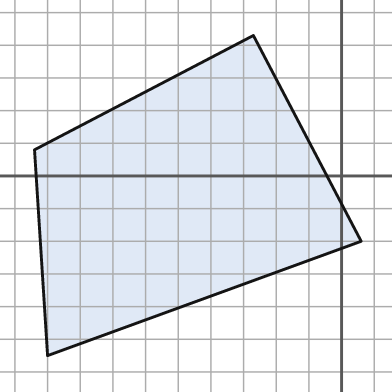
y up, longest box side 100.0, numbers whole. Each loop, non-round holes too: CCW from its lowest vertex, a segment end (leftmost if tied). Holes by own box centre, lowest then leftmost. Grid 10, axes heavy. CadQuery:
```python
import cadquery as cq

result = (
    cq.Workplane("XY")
    .moveTo(-90.0, -55.0)
    .lineTo(6.0, -20.0)
    .lineTo(-27.0, 43.0)
    .lineTo(-94.0, 8.0)
    .close()
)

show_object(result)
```